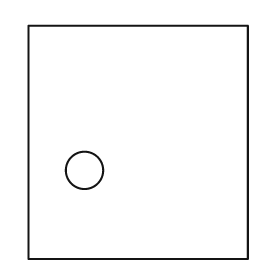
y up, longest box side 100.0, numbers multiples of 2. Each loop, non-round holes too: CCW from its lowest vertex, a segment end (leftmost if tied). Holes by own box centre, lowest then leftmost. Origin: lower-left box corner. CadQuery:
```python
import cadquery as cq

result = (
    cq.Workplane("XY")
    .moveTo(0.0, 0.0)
    .lineTo(94.0, 0.0)
    .lineTo(94.0, 100.0)
    .lineTo(0.0, 100.0)
    .close()
    .moveTo(24.0, 38.0)
    .circle(8.0)
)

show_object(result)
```